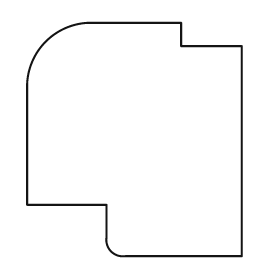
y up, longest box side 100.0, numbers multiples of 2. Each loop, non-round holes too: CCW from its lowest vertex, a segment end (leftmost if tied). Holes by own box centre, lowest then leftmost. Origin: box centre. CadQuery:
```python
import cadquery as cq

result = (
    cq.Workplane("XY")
    .moveTo(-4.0, -50.0)
    .lineTo(46.0, -50.0)
    .lineTo(46.0, 40.0)
    .lineTo(20.0, 40.0)
    .lineTo(20.0, 50.0)
    .lineTo(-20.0, 50.0)
    .threePointArc((-38.0, 42.0), (-46.0, 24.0))
    .lineTo(-46.0, -28.0)
    .lineTo(-12.0, -28.0)
    .lineTo(-12.0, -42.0)
    .threePointArc((-10.0, -48.0), (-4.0, -50.0))
    .close()
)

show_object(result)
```